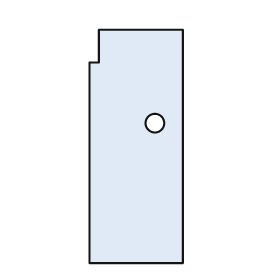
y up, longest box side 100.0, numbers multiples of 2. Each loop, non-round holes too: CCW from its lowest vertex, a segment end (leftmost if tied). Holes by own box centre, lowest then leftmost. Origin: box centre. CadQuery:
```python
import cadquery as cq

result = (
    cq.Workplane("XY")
    .moveTo(-20.0, -50.0)
    .lineTo(20.0, -50.0)
    .lineTo(20.0, 50.0)
    .lineTo(-16.0, 50.0)
    .lineTo(-16.0, 36.0)
    .lineTo(-20.0, 36.0)
    .close()
    .moveTo(8.0, 10.0)
    .circle(4.0)
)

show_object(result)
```